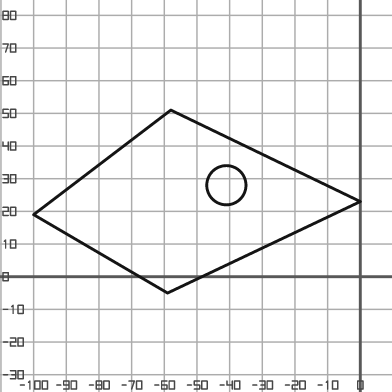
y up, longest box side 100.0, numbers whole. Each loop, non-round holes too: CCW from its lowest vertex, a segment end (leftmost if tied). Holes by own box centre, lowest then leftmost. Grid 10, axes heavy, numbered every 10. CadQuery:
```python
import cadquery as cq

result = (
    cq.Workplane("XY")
    .moveTo(-59.0, -5.0)
    .lineTo(0.0, 23.0)
    .lineTo(-58.0, 51.0)
    .lineTo(-100.0, 19.0)
    .close()
    .moveTo(-41.0, 28.0)
    .circle(6.0)
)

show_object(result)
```